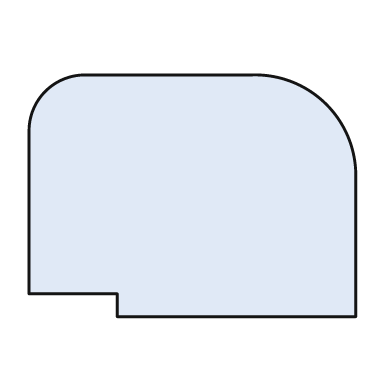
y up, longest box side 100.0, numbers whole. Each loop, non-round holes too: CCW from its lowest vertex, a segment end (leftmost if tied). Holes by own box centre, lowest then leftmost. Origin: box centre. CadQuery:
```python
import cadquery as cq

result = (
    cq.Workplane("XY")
    .moveTo(-23.0, -37.0)
    .lineTo(50.0, -37.0)
    .lineTo(50.0, 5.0)
    .threePointArc((41.0, 28.0), (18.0, 37.0))
    .lineTo(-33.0, 37.0)
    .threePointArc((-45.0, 32.0), (-50.0, 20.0))
    .lineTo(-50.0, -30.0)
    .lineTo(-23.0, -30.0)
    .close()
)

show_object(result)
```